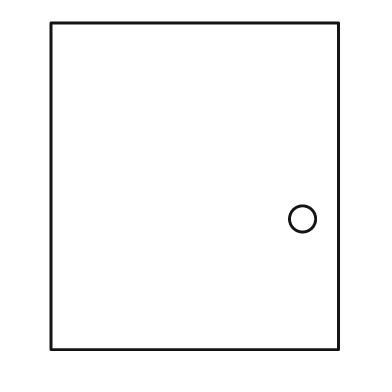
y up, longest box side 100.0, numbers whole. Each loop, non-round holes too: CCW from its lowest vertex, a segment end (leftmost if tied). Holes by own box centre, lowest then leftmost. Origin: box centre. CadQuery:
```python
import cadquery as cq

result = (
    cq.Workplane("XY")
    .moveTo(-44.0, -50.0)
    .lineTo(44.0, -50.0)
    .lineTo(44.0, 50.0)
    .lineTo(-44.0, 50.0)
    .close()
    .moveTo(33.0, -10.0)
    .circle(4.0)
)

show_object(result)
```